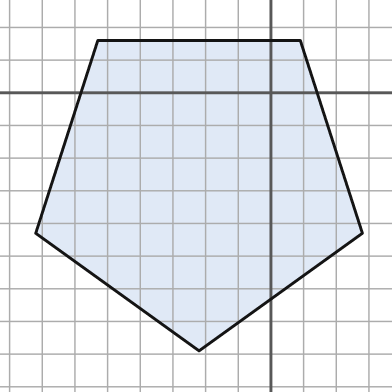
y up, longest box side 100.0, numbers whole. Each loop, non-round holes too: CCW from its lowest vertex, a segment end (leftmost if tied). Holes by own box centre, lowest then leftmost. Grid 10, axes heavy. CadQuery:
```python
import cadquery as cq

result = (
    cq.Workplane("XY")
    .moveTo(-22.0, -79.0)
    .lineTo(28.0, -43.0)
    .lineTo(9.0, 16.0)
    .lineTo(-53.0, 16.0)
    .lineTo(-72.0, -43.0)
    .close()
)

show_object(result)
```